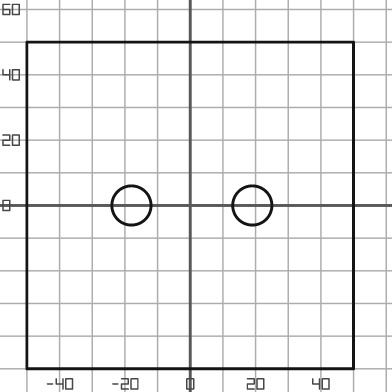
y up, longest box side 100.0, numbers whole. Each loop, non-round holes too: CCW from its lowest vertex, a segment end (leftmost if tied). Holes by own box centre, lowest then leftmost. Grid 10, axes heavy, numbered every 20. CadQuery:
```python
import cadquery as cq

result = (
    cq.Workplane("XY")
    .moveTo(-50.0, -50.0)
    .lineTo(50.0, -50.0)
    .lineTo(50.0, 50.0)
    .lineTo(-50.0, 50.0)
    .close()
    .moveTo(-18.0, 0.0)
    .circle(6.0)
    .moveTo(19.0, 0.0)
    .circle(6.0)
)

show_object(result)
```